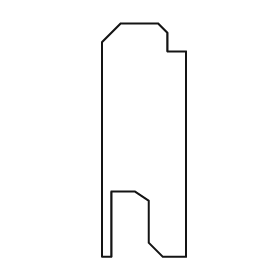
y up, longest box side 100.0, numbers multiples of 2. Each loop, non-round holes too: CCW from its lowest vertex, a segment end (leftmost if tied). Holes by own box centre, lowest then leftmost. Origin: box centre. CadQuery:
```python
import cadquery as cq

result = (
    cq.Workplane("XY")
    .moveTo(-18.0, -50.0)
    .lineTo(-14.0, -50.0)
    .lineTo(-14.0, -22.0)
    .lineTo(-4.0, -22.0)
    .lineTo(2.0, -26.0)
    .lineTo(2.0, -44.0)
    .lineTo(8.0, -50.0)
    .lineTo(18.0, -50.0)
    .lineTo(18.0, 38.0)
    .lineTo(10.0, 38.0)
    .lineTo(10.0, 46.0)
    .lineTo(6.0, 50.0)
    .lineTo(-10.0, 50.0)
    .lineTo(-18.0, 42.0)
    .close()
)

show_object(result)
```